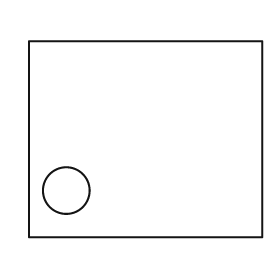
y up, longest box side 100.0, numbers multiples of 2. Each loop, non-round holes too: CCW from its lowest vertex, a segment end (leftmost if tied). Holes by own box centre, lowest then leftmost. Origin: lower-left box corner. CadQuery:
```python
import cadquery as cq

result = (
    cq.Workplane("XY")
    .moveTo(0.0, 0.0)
    .lineTo(100.0, 0.0)
    .lineTo(100.0, 84.0)
    .lineTo(0.0, 84.0)
    .close()
    .moveTo(16.0, 20.0)
    .circle(10.0)
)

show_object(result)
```